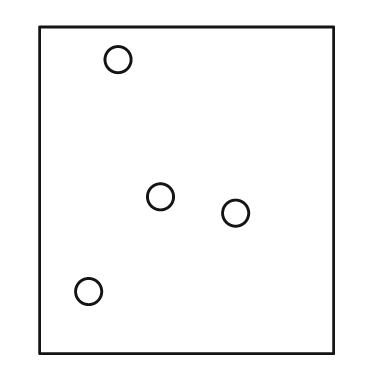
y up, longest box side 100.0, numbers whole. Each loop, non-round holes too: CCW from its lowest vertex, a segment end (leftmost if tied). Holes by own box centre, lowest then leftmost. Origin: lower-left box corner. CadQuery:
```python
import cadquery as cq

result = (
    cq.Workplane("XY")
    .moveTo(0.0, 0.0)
    .lineTo(90.0, 0.0)
    .lineTo(90.0, 100.0)
    .lineTo(0.0, 100.0)
    .close()
    .moveTo(15.0, 19.0)
    .circle(4.0)
    .moveTo(60.0, 43.0)
    .circle(4.0)
    .moveTo(37.0, 48.0)
    .circle(4.0)
    .moveTo(24.0, 90.0)
    .circle(4.0)
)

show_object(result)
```